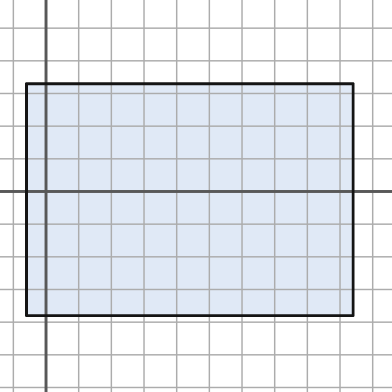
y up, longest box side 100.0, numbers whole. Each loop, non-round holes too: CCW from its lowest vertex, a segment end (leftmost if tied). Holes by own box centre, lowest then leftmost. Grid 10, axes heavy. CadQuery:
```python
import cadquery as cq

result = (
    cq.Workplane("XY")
    .moveTo(-6.0, -38.0)
    .lineTo(94.0, -38.0)
    .lineTo(94.0, 33.0)
    .lineTo(-6.0, 33.0)
    .close()
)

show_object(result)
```